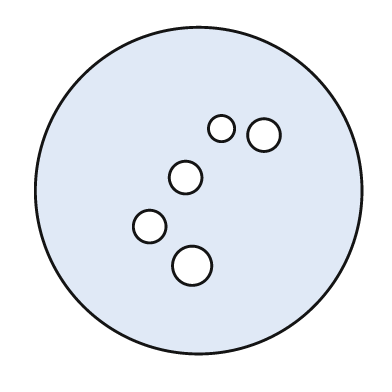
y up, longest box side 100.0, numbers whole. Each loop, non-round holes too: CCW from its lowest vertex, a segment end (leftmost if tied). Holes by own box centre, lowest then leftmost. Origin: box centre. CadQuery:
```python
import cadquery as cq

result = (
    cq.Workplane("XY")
    .moveTo(0.0, 0.0)
    .circle(50.0)
    .moveTo(-2.0, -23.0)
    .circle(6.0)
    .moveTo(-15.0, -11.0)
    .circle(5.0)
    .moveTo(-4.0, 4.0)
    .circle(5.0)
    .moveTo(20.0, 17.0)
    .circle(5.0)
    .moveTo(7.0, 19.0)
    .circle(4.0)
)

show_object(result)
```